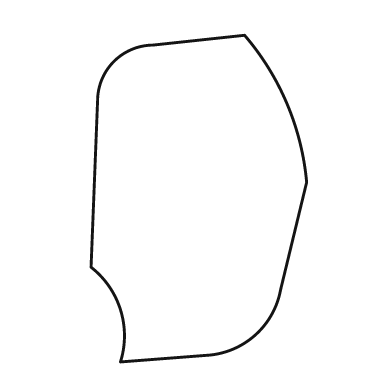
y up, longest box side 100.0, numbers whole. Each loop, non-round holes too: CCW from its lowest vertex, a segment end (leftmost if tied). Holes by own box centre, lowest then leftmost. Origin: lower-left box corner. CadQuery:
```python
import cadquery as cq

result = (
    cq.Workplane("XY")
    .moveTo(9.0, 0.0)
    .lineTo(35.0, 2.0)
    .threePointArc((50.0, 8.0), (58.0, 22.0))
    .lineTo(66.0, 55.0)
    .threePointArc((60.0, 79.0), (47.0, 100.0))
    .lineTo(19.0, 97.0)
    .threePointArc((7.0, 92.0), (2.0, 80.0))
    .lineTo(0.0, 29.0)
    .threePointArc((9.0, 16.0), (9.0, 0.0))
    .close()
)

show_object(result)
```